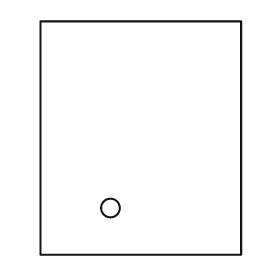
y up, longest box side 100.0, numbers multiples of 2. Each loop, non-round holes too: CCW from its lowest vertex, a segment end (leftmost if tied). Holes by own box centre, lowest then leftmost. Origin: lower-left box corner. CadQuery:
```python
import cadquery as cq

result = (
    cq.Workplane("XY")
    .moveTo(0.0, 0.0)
    .lineTo(86.0, 0.0)
    .lineTo(86.0, 100.0)
    .lineTo(0.0, 100.0)
    .close()
    .moveTo(30.0, 20.0)
    .circle(4.0)
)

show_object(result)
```